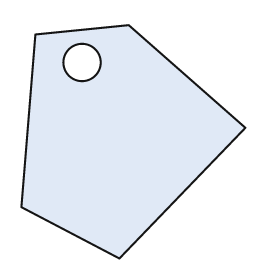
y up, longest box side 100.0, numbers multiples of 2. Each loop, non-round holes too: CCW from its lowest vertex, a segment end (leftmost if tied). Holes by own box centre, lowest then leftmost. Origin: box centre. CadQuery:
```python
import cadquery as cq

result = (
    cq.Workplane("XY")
    .moveTo(-6.0, -50.0)
    .lineTo(48.0, 6.0)
    .lineTo(-2.0, 50.0)
    .lineTo(-42.0, 46.0)
    .lineTo(-48.0, -28.0)
    .close()
    .moveTo(-22.0, 34.0)
    .circle(8.0)
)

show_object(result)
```